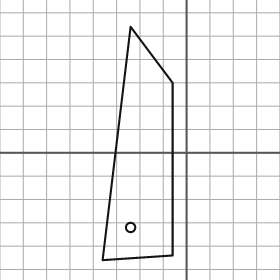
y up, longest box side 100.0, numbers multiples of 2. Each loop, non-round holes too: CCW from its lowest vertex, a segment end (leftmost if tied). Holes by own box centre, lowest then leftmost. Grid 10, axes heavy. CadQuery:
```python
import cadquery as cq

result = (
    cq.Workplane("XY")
    .moveTo(-36.0, -46.0)
    .lineTo(-6.0, -44.0)
    .lineTo(-6.0, 30.0)
    .lineTo(-24.0, 54.0)
    .close()
    .moveTo(-24.0, -32.0)
    .circle(2.0)
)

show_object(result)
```